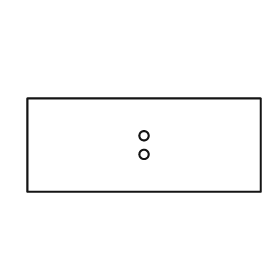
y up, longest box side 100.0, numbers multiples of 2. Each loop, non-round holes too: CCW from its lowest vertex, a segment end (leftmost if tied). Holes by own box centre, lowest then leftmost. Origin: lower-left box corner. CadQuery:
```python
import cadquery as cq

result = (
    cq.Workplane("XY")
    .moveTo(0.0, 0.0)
    .lineTo(100.0, 0.0)
    .lineTo(100.0, 40.0)
    .lineTo(0.0, 40.0)
    .close()
    .moveTo(50.0, 16.0)
    .circle(2.0)
    .moveTo(50.0, 24.0)
    .circle(2.0)
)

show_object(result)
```